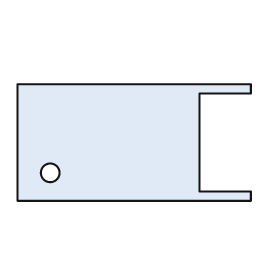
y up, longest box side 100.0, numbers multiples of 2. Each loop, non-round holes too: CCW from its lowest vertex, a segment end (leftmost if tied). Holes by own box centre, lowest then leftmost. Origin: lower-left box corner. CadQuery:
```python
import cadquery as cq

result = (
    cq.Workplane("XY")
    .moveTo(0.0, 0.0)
    .lineTo(100.0, 0.0)
    .lineTo(100.0, 4.0)
    .lineTo(78.0, 4.0)
    .lineTo(78.0, 46.0)
    .lineTo(100.0, 46.0)
    .lineTo(100.0, 50.0)
    .lineTo(0.0, 50.0)
    .close()
    .moveTo(14.0, 12.0)
    .circle(4.0)
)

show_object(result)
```